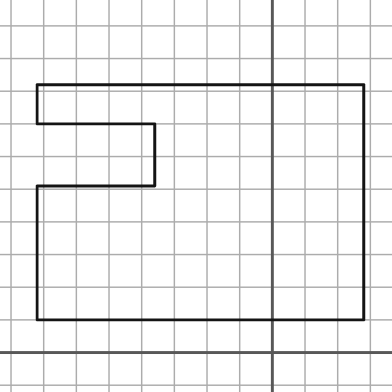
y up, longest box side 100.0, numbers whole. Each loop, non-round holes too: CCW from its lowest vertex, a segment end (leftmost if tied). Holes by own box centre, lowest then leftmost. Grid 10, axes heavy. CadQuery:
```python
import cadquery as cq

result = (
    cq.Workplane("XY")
    .moveTo(-72.0, 10.0)
    .lineTo(28.0, 10.0)
    .lineTo(28.0, 82.0)
    .lineTo(-72.0, 82.0)
    .lineTo(-72.0, 70.0)
    .lineTo(-36.0, 70.0)
    .lineTo(-36.0, 51.0)
    .lineTo(-72.0, 51.0)
    .close()
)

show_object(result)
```